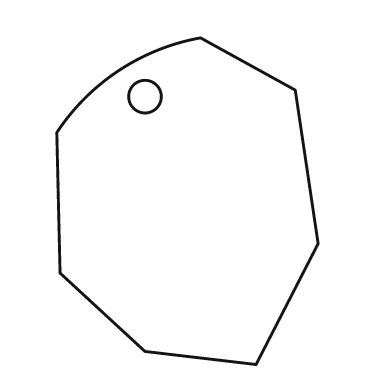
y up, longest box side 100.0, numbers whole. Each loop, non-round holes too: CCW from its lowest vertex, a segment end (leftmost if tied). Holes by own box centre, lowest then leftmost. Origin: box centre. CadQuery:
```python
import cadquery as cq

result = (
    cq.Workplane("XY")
    .moveTo(21.0, -50.0)
    .lineTo(40.0, -13.0)
    .lineTo(33.0, 34.0)
    .lineTo(4.0, 50.0)
    .threePointArc((-21.0, 40.0), (-40.0, 21.0))
    .lineTo(-39.0, -22.0)
    .lineTo(-13.0, -46.0)
    .close()
    .moveTo(-13.0, 32.0)
    .circle(5.0)
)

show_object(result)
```